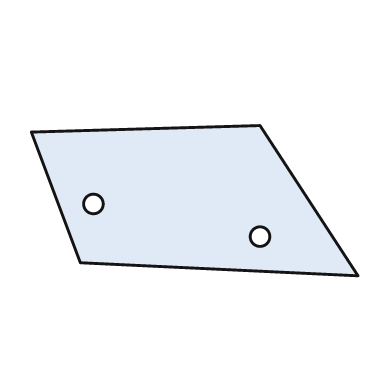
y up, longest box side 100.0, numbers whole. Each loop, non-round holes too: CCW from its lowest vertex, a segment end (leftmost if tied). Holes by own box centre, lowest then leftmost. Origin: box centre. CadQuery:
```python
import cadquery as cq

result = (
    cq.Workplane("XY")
    .moveTo(50.0, -23.0)
    .lineTo(20.0, 23.0)
    .lineTo(-50.0, 21.0)
    .lineTo(-35.0, -19.0)
    .close()
    .moveTo(20.0, -11.0)
    .circle(3.0)
    .moveTo(-31.0, -1.0)
    .circle(3.0)
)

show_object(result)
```